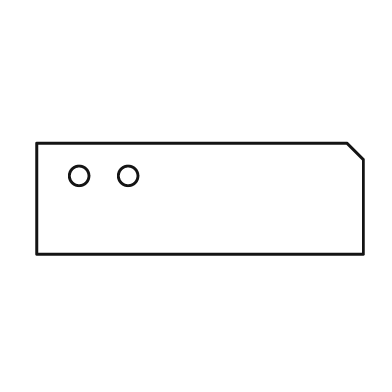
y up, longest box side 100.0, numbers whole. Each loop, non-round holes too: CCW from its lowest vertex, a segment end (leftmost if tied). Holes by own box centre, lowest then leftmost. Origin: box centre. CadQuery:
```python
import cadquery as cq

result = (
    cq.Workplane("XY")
    .moveTo(-50.0, -17.0)
    .lineTo(50.0, -17.0)
    .lineTo(50.0, 12.0)
    .lineTo(45.0, 17.0)
    .lineTo(-50.0, 17.0)
    .close()
    .moveTo(-37.0, 7.0)
    .circle(3.0)
    .moveTo(-22.0, 7.0)
    .circle(3.0)
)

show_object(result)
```